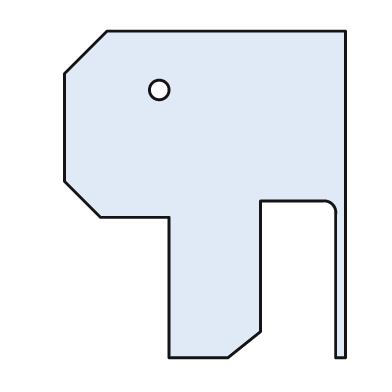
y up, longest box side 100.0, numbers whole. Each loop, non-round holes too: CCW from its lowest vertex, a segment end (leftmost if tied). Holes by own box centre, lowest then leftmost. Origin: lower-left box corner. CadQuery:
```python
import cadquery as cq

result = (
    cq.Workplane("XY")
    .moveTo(32.0, 0.0)
    .lineTo(50.0, 0.0)
    .lineTo(60.0, 8.0)
    .lineTo(60.0, 48.0)
    .lineTo(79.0, 48.0)
    .threePointArc((82.0, 47.0), (83.0, 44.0))
    .lineTo(83.0, 0.0)
    .lineTo(86.0, 0.0)
    .lineTo(86.0, 100.0)
    .lineTo(13.0, 100.0)
    .lineTo(0.0, 87.0)
    .lineTo(0.0, 54.0)
    .lineTo(11.0, 43.0)
    .lineTo(32.0, 43.0)
    .close()
    .moveTo(29.0, 82.0)
    .circle(3.0)
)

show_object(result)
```